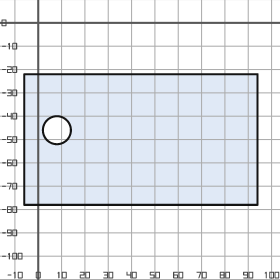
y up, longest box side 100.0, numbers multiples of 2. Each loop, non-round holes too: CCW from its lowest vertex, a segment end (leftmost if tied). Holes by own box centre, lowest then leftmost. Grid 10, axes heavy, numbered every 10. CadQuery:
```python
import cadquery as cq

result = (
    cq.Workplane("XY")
    .moveTo(-6.0, -78.0)
    .lineTo(94.0, -78.0)
    .lineTo(94.0, -22.0)
    .lineTo(-6.0, -22.0)
    .close()
    .moveTo(8.0, -46.0)
    .circle(6.0)
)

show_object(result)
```